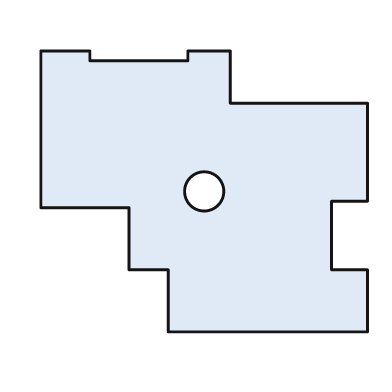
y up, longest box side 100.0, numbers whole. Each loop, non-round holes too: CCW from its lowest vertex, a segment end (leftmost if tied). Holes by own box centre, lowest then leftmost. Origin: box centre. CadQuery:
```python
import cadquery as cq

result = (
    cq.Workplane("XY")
    .moveTo(-11.0, -43.0)
    .lineTo(50.0, -43.0)
    .lineTo(50.0, -24.0)
    .lineTo(39.0, -24.0)
    .lineTo(39.0, -3.0)
    .lineTo(50.0, -3.0)
    .lineTo(50.0, 27.0)
    .lineTo(8.0, 27.0)
    .lineTo(8.0, 43.0)
    .lineTo(-5.0, 43.0)
    .lineTo(-5.0, 40.0)
    .lineTo(-35.0, 40.0)
    .lineTo(-35.0, 43.0)
    .lineTo(-50.0, 43.0)
    .lineTo(-50.0, -5.0)
    .lineTo(-23.0, -5.0)
    .lineTo(-23.0, -24.0)
    .lineTo(-11.0, -24.0)
    .close()
    .moveTo(0.0, 0.0)
    .circle(6.0)
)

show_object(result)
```